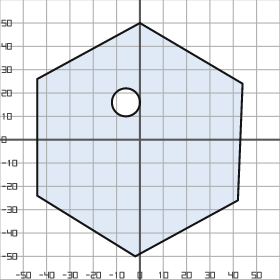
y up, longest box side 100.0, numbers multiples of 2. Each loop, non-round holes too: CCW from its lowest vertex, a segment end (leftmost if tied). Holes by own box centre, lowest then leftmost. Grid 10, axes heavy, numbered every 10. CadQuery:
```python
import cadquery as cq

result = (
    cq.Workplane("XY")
    .moveTo(-2.0, -50.0)
    .lineTo(42.0, -26.0)
    .lineTo(44.0, 24.0)
    .lineTo(0.0, 50.0)
    .lineTo(-44.0, 26.0)
    .lineTo(-44.0, -24.0)
    .close()
    .moveTo(-6.0, 16.0)
    .circle(6.0)
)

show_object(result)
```